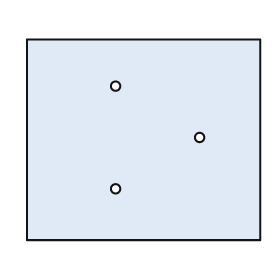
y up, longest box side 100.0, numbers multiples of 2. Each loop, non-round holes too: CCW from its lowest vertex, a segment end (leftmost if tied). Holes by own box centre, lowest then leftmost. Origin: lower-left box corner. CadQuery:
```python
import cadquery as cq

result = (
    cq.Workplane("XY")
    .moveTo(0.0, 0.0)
    .lineTo(100.0, 0.0)
    .lineTo(100.0, 86.0)
    .lineTo(0.0, 86.0)
    .close()
    .moveTo(38.0, 22.0)
    .circle(2.0)
    .moveTo(74.0, 44.0)
    .circle(2.0)
    .moveTo(38.0, 66.0)
    .circle(2.0)
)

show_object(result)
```